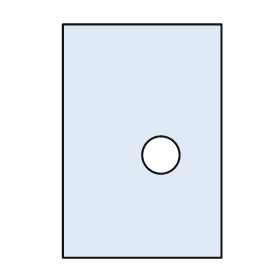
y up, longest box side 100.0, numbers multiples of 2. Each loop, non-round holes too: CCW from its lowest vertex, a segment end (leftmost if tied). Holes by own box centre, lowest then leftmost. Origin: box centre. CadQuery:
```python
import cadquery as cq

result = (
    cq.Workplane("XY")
    .moveTo(-34.0, -50.0)
    .lineTo(34.0, -50.0)
    .lineTo(34.0, 50.0)
    .lineTo(-34.0, 50.0)
    .close()
    .moveTo(8.0, -6.0)
    .circle(8.0)
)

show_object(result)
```